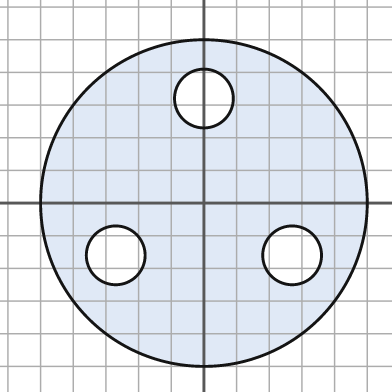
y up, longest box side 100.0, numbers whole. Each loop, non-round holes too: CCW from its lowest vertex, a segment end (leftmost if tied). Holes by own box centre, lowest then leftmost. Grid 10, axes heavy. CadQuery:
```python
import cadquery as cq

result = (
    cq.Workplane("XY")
    .moveTo(0.0, 0.0)
    .circle(50.0)
    .moveTo(-27.0, -16.0)
    .circle(9.0)
    .moveTo(27.0, -16.0)
    .circle(9.0)
    .moveTo(0.0, 32.0)
    .circle(9.0)
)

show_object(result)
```